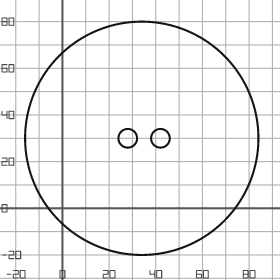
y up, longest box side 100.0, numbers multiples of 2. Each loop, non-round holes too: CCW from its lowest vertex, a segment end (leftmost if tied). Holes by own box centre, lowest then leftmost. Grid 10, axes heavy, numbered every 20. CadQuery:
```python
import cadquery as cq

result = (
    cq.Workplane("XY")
    .moveTo(34.0, 30.0)
    .circle(50.0)
    .moveTo(28.0, 30.0)
    .circle(4.0)
    .moveTo(42.0, 30.0)
    .circle(4.0)
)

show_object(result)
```